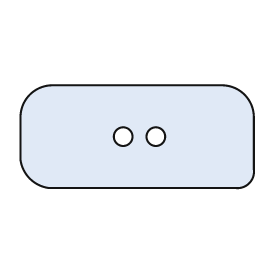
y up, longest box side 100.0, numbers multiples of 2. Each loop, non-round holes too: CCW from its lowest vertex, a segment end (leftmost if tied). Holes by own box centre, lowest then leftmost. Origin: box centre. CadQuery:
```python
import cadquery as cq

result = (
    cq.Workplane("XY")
    .moveTo(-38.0, -22.0)
    .lineTo(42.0, -22.0)
    .threePointArc((48.0, -20.0), (50.0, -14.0))
    .lineTo(50.0, 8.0)
    .threePointArc((46.0, 18.0), (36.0, 22.0))
    .lineTo(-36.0, 22.0)
    .threePointArc((-46.0, 18.0), (-50.0, 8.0))
    .lineTo(-50.0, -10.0)
    .threePointArc((-46.0, -18.0), (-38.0, -22.0))
    .close()
    .moveTo(-6.0, 0.0)
    .circle(4.0)
    .moveTo(8.0, 0.0)
    .circle(4.0)
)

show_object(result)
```